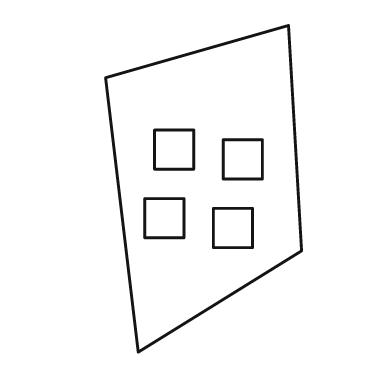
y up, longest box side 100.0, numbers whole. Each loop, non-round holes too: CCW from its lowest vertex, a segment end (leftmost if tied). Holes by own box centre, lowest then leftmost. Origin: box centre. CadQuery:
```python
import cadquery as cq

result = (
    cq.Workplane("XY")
    .moveTo(-20.0, -50.0)
    .lineTo(30.0, -19.0)
    .lineTo(26.0, 50.0)
    .lineTo(-30.0, 34.0)
    .close()
    .moveTo(3.0, -18.0)
    .lineTo(15.0, -18.0)
    .lineTo(15.0, -6.0)
    .lineTo(3.0, -6.0)
    .close()
    .moveTo(-18.0, -15.0)
    .lineTo(-6.0, -15.0)
    .lineTo(-6.0, -3.0)
    .lineTo(-18.0, -3.0)
    .close()
    .moveTo(6.0, 3.0)
    .lineTo(18.0, 3.0)
    .lineTo(18.0, 15.0)
    .lineTo(6.0, 15.0)
    .close()
    .moveTo(-15.0, 6.0)
    .lineTo(-3.0, 6.0)
    .lineTo(-3.0, 18.0)
    .lineTo(-15.0, 18.0)
    .close()
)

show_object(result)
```